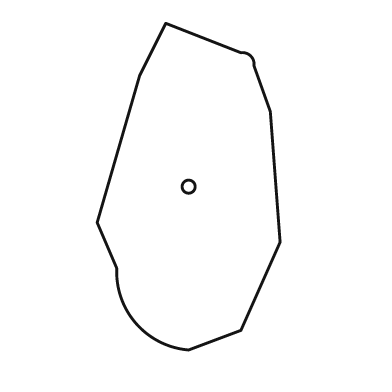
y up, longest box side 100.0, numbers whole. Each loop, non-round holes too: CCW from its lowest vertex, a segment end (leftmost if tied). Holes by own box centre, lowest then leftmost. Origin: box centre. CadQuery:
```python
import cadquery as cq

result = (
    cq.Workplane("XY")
    .moveTo(0.0, -50.0)
    .lineTo(16.0, -44.0)
    .lineTo(28.0, -17.0)
    .lineTo(25.0, 23.0)
    .lineTo(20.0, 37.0)
    .threePointArc((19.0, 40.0), (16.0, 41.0))
    .lineTo(-7.0, 50.0)
    .lineTo(-15.0, 34.0)
    .lineTo(-28.0, -11.0)
    .lineTo(-22.0, -25.0)
    .threePointArc((-16.0, -42.0), (0.0, -50.0))
    .close()
    .moveTo(0.0, 0.0)
    .circle(2.0)
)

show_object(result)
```